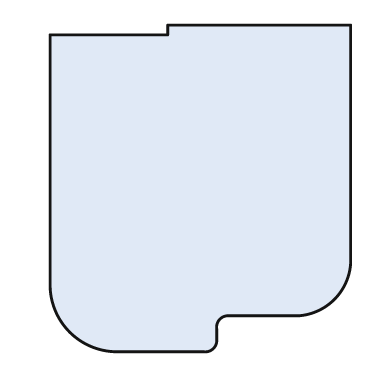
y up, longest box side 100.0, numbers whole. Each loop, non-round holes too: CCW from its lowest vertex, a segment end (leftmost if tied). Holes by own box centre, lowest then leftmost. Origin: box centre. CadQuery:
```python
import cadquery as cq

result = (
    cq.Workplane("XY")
    .moveTo(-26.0, -50.0)
    .lineTo(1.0, -50.0)
    .threePointArc((4.0, -49.0), (5.0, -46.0))
    .lineTo(5.0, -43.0)
    .threePointArc((6.0, -40.0), (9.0, -39.0))
    .lineTo(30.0, -39.0)
    .threePointArc((41.0, -34.0), (46.0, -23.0))
    .lineTo(46.0, 50.0)
    .lineTo(-10.0, 50.0)
    .lineTo(-10.0, 47.0)
    .lineTo(-46.0, 47.0)
    .lineTo(-46.0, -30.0)
    .threePointArc((-40.0, -44.0), (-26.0, -50.0))
    .close()
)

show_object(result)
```